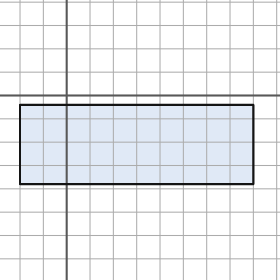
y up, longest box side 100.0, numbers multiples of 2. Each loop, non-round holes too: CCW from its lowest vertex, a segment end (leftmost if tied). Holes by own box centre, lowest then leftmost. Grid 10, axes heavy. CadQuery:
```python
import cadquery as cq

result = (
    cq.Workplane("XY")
    .moveTo(-20.0, -38.0)
    .lineTo(80.0, -38.0)
    .lineTo(80.0, -4.0)
    .lineTo(-20.0, -4.0)
    .close()
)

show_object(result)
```